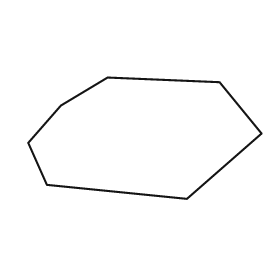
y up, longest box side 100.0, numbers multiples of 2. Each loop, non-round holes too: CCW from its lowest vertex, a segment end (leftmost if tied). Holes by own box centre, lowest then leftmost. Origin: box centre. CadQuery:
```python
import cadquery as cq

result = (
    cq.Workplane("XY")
    .moveTo(18.0, -26.0)
    .lineTo(50.0, 2.0)
    .lineTo(32.0, 24.0)
    .lineTo(-16.0, 26.0)
    .lineTo(-36.0, 14.0)
    .lineTo(-50.0, -2.0)
    .lineTo(-42.0, -20.0)
    .close()
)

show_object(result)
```